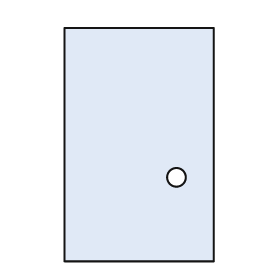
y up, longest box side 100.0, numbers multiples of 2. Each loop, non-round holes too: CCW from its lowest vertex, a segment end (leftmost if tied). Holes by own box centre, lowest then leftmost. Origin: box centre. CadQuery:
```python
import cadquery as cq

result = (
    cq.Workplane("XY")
    .moveTo(-32.0, -50.0)
    .lineTo(32.0, -50.0)
    .lineTo(32.0, 50.0)
    .lineTo(-32.0, 50.0)
    .close()
    .moveTo(16.0, -14.0)
    .circle(4.0)
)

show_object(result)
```